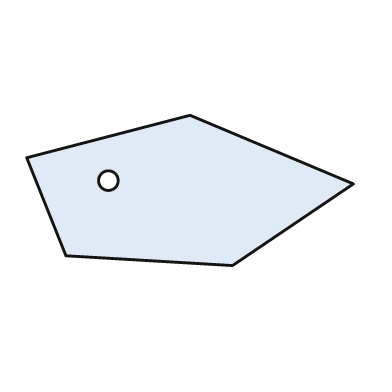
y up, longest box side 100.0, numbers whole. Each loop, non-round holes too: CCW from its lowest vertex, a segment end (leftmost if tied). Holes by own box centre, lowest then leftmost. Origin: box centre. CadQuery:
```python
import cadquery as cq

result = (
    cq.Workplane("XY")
    .moveTo(13.0, -23.0)
    .lineTo(50.0, 2.0)
    .lineTo(0.0, 23.0)
    .lineTo(-50.0, 10.0)
    .lineTo(-38.0, -20.0)
    .close()
    .moveTo(-25.0, 3.0)
    .circle(3.0)
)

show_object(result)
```